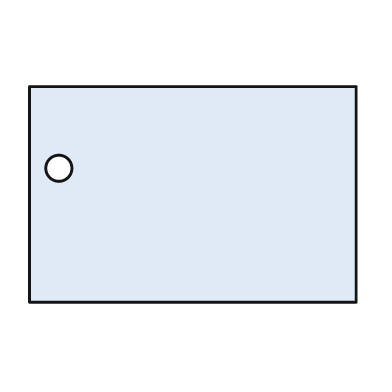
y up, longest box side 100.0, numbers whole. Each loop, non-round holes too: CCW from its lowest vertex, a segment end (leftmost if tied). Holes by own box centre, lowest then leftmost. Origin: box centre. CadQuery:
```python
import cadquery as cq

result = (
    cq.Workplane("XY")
    .moveTo(-50.0, -33.0)
    .lineTo(50.0, -33.0)
    .lineTo(50.0, 33.0)
    .lineTo(-50.0, 33.0)
    .close()
    .moveTo(-41.0, 8.0)
    .circle(4.0)
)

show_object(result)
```